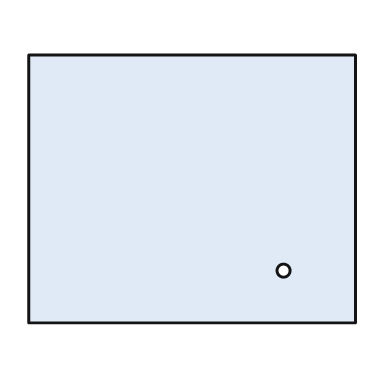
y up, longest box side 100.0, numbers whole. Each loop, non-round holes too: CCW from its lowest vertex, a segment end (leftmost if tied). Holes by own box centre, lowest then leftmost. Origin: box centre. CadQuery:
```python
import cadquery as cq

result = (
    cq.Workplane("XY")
    .moveTo(-50.0, -41.0)
    .lineTo(50.0, -41.0)
    .lineTo(50.0, 41.0)
    .lineTo(-50.0, 41.0)
    .close()
    .moveTo(28.0, -25.0)
    .circle(2.0)
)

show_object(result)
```